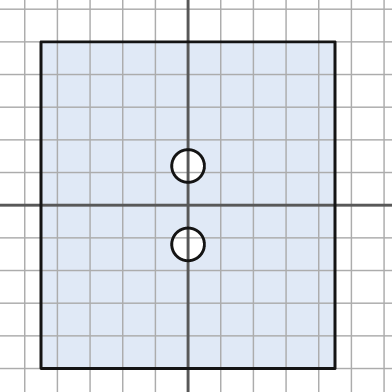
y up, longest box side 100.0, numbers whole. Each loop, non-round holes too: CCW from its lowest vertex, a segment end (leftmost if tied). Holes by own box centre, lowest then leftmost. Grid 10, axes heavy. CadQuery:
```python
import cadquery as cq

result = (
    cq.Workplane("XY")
    .moveTo(-45.0, -50.0)
    .lineTo(45.0, -50.0)
    .lineTo(45.0, 50.0)
    .lineTo(-45.0, 50.0)
    .close()
    .moveTo(0.0, -12.0)
    .circle(5.0)
    .moveTo(0.0, 12.0)
    .circle(5.0)
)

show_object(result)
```